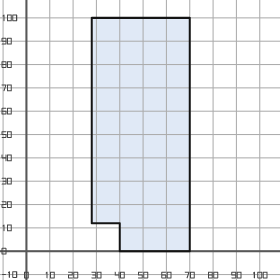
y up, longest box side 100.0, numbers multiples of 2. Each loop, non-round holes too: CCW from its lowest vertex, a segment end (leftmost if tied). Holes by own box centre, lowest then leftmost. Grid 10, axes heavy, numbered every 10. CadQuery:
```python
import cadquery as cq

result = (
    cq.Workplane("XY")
    .moveTo(40.0, 0.0)
    .lineTo(70.0, 0.0)
    .lineTo(70.0, 100.0)
    .lineTo(28.0, 100.0)
    .lineTo(28.0, 12.0)
    .lineTo(40.0, 12.0)
    .close()
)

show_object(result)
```